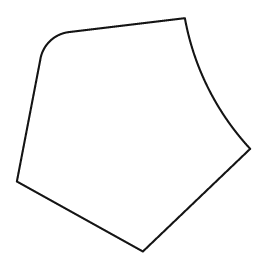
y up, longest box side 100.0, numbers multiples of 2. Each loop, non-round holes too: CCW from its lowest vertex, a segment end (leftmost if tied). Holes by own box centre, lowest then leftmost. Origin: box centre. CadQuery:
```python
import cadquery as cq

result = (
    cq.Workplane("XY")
    .moveTo(4.0, -50.0)
    .lineTo(50.0, -6.0)
    .threePointArc((32.0, 20.0), (22.0, 50.0))
    .lineTo(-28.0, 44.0)
    .threePointArc((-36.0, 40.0), (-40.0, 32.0))
    .lineTo(-50.0, -20.0)
    .close()
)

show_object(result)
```